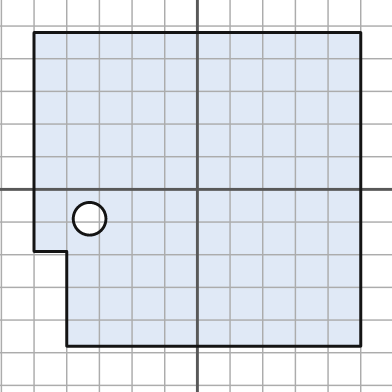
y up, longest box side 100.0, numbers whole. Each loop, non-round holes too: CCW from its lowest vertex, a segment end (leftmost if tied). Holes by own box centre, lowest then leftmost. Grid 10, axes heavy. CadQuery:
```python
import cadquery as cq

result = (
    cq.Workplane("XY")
    .moveTo(-40.0, -48.0)
    .lineTo(50.0, -48.0)
    .lineTo(50.0, 48.0)
    .lineTo(-50.0, 48.0)
    .lineTo(-50.0, -19.0)
    .lineTo(-40.0, -19.0)
    .close()
    .moveTo(-33.0, -9.0)
    .circle(5.0)
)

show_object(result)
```